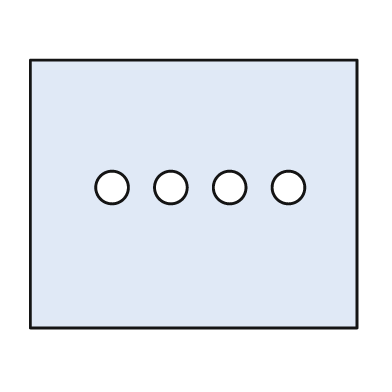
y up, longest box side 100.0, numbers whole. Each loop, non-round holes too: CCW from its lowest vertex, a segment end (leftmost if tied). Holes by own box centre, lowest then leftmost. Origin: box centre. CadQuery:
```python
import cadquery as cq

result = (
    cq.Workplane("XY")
    .moveTo(-50.0, -41.0)
    .lineTo(50.0, -41.0)
    .lineTo(50.0, 41.0)
    .lineTo(-50.0, 41.0)
    .close()
    .moveTo(-25.0, 2.0)
    .circle(5.0)
    .moveTo(-7.0, 2.0)
    .circle(5.0)
    .moveTo(11.0, 2.0)
    .circle(5.0)
    .moveTo(29.0, 2.0)
    .circle(5.0)
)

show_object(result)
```